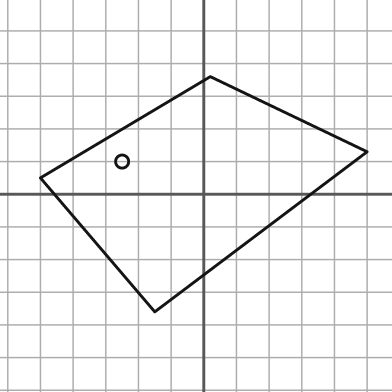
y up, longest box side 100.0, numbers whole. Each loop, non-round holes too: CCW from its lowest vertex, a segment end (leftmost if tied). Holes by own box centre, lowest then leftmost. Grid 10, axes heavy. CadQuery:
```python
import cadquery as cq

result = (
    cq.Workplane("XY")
    .moveTo(-15.0, -36.0)
    .lineTo(50.0, 13.0)
    .lineTo(2.0, 36.0)
    .lineTo(-50.0, 5.0)
    .close()
    .moveTo(-25.0, 10.0)
    .circle(2.0)
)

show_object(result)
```